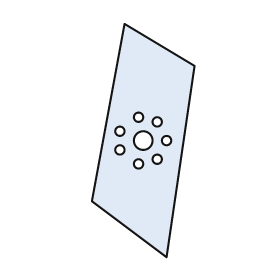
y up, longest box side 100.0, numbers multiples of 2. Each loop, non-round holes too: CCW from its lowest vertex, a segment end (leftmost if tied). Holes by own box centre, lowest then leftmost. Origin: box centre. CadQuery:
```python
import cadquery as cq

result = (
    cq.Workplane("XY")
    .moveTo(10.0, -50.0)
    .lineTo(22.0, 32.0)
    .lineTo(-8.0, 50.0)
    .lineTo(-22.0, -26.0)
    .close()
    .moveTo(-2.0, -10.0)
    .circle(2.0)
    .moveTo(6.0, -8.0)
    .circle(2.0)
    .moveTo(-10.0, -4.0)
    .circle(2.0)
    .moveTo(0.0, 0.0)
    .circle(4.0)
    .moveTo(10.0, 0.0)
    .circle(2.0)
    .moveTo(-10.0, 4.0)
    .circle(2.0)
    .moveTo(6.0, 8.0)
    .circle(2.0)
    .moveTo(-2.0, 10.0)
    .circle(2.0)
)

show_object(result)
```